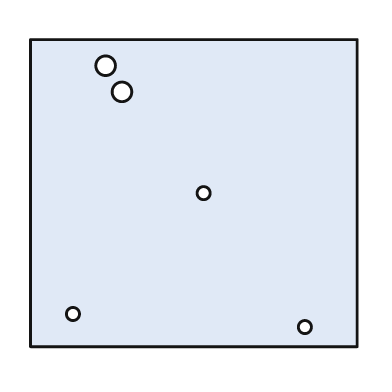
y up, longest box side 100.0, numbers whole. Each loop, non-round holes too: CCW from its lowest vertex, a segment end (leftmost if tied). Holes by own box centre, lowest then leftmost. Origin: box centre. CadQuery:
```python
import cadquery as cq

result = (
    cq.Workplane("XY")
    .moveTo(-50.0, -47.0)
    .lineTo(50.0, -47.0)
    .lineTo(50.0, 47.0)
    .lineTo(-50.0, 47.0)
    .close()
    .moveTo(34.0, -41.0)
    .circle(2.0)
    .moveTo(-37.0, -37.0)
    .circle(2.0)
    .moveTo(3.0, 0.0)
    .circle(2.0)
    .moveTo(-22.0, 31.0)
    .circle(3.0)
    .moveTo(-27.0, 39.0)
    .circle(3.0)
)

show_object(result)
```